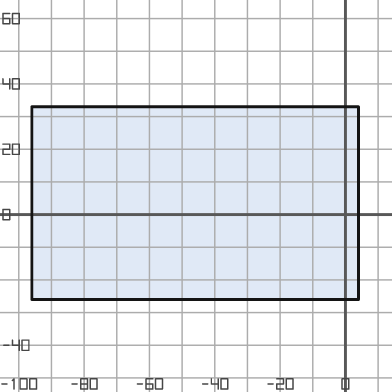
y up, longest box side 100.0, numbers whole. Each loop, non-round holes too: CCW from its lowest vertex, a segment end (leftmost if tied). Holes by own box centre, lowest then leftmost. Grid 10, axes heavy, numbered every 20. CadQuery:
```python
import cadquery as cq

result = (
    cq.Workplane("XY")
    .moveTo(-96.0, -26.0)
    .lineTo(4.0, -26.0)
    .lineTo(4.0, 33.0)
    .lineTo(-96.0, 33.0)
    .close()
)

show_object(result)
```